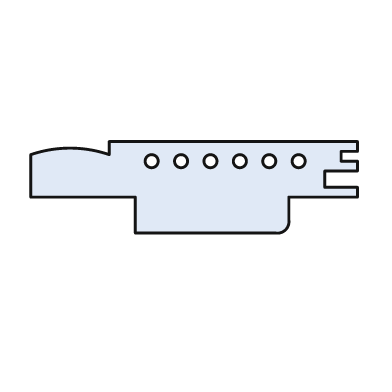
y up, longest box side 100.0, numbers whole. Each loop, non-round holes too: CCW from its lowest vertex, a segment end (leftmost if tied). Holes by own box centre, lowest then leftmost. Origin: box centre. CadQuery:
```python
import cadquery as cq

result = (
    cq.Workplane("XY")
    .moveTo(-18.0, -14.0)
    .lineTo(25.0, -14.0)
    .threePointArc((28.0, -13.0), (29.0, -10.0))
    .lineTo(29.0, -3.0)
    .lineTo(50.0, -3.0)
    .lineTo(50.0, 0.0)
    .lineTo(40.0, 0.0)
    .lineTo(40.0, 5.0)
    .lineTo(50.0, 5.0)
    .lineTo(50.0, 8.0)
    .lineTo(45.0, 8.0)
    .lineTo(45.0, 11.0)
    .lineTo(50.0, 11.0)
    .lineTo(50.0, 14.0)
    .lineTo(-26.0, 14.0)
    .lineTo(-26.0, 10.0)
    .threePointArc((-38.0, 12.0), (-50.0, 10.0))
    .lineTo(-50.0, -3.0)
    .lineTo(-18.0, -3.0)
    .close()
    .moveTo(-13.0, 8.0)
    .circle(2.0)
    .moveTo(-4.0, 8.0)
    .circle(2.0)
    .moveTo(5.0, 8.0)
    .circle(2.0)
    .moveTo(14.0, 8.0)
    .circle(2.0)
    .moveTo(23.0, 8.0)
    .circle(2.0)
    .moveTo(32.0, 8.0)
    .circle(2.0)
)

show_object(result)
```